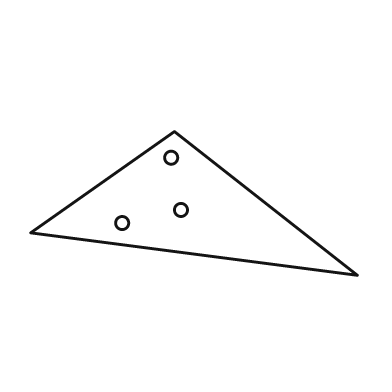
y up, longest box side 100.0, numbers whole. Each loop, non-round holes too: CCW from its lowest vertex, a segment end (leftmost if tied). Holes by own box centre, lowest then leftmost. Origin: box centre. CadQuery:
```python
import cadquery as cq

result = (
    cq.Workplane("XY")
    .moveTo(50.0, -22.0)
    .lineTo(-6.0, 22.0)
    .lineTo(-50.0, -9.0)
    .close()
    .moveTo(-22.0, -6.0)
    .circle(2.0)
    .moveTo(-4.0, -2.0)
    .circle(2.0)
    .moveTo(-7.0, 14.0)
    .circle(2.0)
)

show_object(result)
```